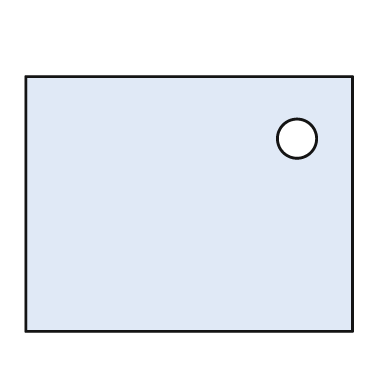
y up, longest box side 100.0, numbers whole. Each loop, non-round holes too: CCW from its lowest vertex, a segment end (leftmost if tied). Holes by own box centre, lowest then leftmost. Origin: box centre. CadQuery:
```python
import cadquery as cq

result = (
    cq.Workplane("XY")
    .moveTo(-50.0, -39.0)
    .lineTo(50.0, -39.0)
    .lineTo(50.0, 39.0)
    .lineTo(-50.0, 39.0)
    .close()
    .moveTo(33.0, 20.0)
    .circle(6.0)
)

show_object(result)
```